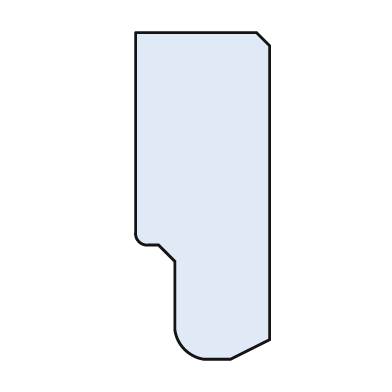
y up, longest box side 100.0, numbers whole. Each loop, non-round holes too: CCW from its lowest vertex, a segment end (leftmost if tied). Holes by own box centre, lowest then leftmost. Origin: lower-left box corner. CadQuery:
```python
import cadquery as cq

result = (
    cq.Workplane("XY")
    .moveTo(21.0, 0.0)
    .lineTo(29.0, 0.0)
    .lineTo(41.0, 6.0)
    .lineTo(41.0, 96.0)
    .lineTo(37.0, 100.0)
    .lineTo(0.0, 100.0)
    .lineTo(0.0, 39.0)
    .threePointArc((1.0, 36.0), (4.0, 35.0))
    .lineTo(7.0, 35.0)
    .lineTo(12.0, 30.0)
    .lineTo(12.0, 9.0)
    .threePointArc((15.0, 3.0), (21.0, 0.0))
    .close()
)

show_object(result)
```